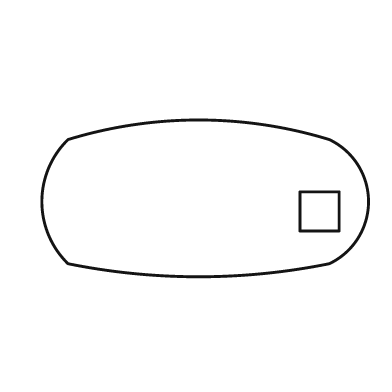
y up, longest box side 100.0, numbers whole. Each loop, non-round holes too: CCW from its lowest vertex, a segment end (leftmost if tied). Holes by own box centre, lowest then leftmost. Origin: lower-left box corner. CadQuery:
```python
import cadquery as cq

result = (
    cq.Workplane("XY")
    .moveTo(8.0, 4.0)
    .threePointArc((48.0, 0.0), (88.0, 4.0))
    .threePointArc((100.0, 23.0), (88.0, 42.0))
    .threePointArc((48.0, 48.0), (8.0, 42.0))
    .threePointArc((0.0, 23.0), (8.0, 4.0))
    .close()
    .moveTo(79.0, 14.0)
    .lineTo(91.0, 14.0)
    .lineTo(91.0, 26.0)
    .lineTo(79.0, 26.0)
    .close()
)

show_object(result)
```